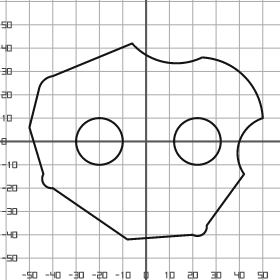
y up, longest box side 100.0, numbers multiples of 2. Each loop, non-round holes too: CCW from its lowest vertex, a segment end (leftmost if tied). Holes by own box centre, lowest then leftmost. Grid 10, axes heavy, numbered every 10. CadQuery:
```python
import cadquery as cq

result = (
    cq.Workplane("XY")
    .moveTo(-8.0, -42.0)
    .lineTo(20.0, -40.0)
    .threePointArc((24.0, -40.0), (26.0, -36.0))
    .lineTo(42.0, -14.0)
    .threePointArc((40.0, 0.0), (50.0, 10.0))
    .threePointArc((42.0, 28.0), (24.0, 36.0))
    .threePointArc((8.0, 34.0), (-6.0, 42.0))
    .lineTo(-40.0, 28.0)
    .threePointArc((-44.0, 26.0), (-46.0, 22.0))
    .lineTo(-50.0, 6.0)
    .lineTo(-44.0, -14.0)
    .threePointArc((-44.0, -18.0), (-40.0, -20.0))
    .close()
    .moveTo(-20.0, 0.0)
    .circle(10.0)
    .moveTo(22.0, 0.0)
    .circle(10.0)
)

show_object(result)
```